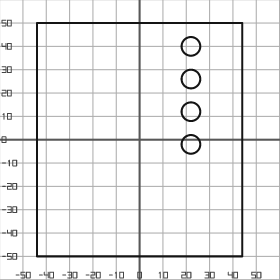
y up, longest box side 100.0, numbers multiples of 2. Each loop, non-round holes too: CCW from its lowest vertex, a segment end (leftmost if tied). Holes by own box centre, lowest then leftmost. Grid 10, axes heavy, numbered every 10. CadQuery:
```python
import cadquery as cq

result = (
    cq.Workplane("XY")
    .moveTo(-44.0, -50.0)
    .lineTo(44.0, -50.0)
    .lineTo(44.0, 50.0)
    .lineTo(-44.0, 50.0)
    .close()
    .moveTo(22.0, -2.0)
    .circle(4.0)
    .moveTo(22.0, 12.0)
    .circle(4.0)
    .moveTo(22.0, 26.0)
    .circle(4.0)
    .moveTo(22.0, 40.0)
    .circle(4.0)
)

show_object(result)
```